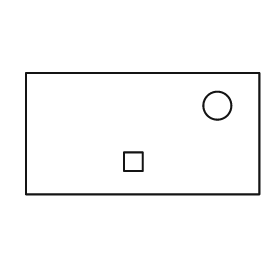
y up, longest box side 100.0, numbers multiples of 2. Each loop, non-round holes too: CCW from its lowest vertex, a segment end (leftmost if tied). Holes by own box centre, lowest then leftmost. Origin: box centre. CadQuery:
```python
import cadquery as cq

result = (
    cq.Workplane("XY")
    .moveTo(-50.0, -26.0)
    .lineTo(50.0, -26.0)
    .lineTo(50.0, 26.0)
    .lineTo(-50.0, 26.0)
    .close()
    .moveTo(-8.0, -16.0)
    .lineTo(0.0, -16.0)
    .lineTo(0.0, -8.0)
    .lineTo(-8.0, -8.0)
    .close()
    .moveTo(32.0, 12.0)
    .circle(6.0)
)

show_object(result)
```